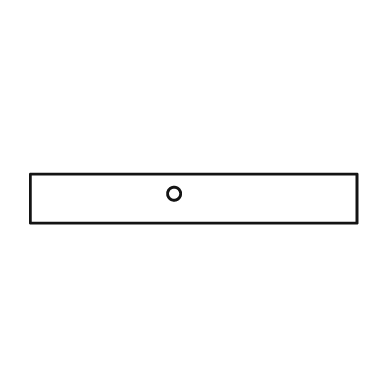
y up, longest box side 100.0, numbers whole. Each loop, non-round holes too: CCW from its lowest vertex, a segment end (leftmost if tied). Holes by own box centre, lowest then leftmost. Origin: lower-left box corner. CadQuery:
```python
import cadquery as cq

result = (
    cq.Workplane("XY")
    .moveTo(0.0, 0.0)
    .lineTo(100.0, 0.0)
    .lineTo(100.0, 15.0)
    .lineTo(0.0, 15.0)
    .close()
    .moveTo(44.0, 9.0)
    .circle(2.0)
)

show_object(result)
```